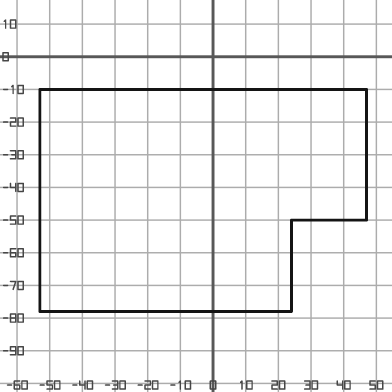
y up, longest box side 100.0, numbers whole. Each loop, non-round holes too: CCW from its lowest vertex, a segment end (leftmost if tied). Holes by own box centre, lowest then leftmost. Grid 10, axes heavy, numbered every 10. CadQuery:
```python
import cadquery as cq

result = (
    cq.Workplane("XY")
    .moveTo(-53.0, -78.0)
    .lineTo(24.0, -78.0)
    .lineTo(24.0, -50.0)
    .lineTo(47.0, -50.0)
    .lineTo(47.0, -10.0)
    .lineTo(-53.0, -10.0)
    .close()
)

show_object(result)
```